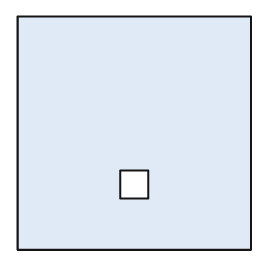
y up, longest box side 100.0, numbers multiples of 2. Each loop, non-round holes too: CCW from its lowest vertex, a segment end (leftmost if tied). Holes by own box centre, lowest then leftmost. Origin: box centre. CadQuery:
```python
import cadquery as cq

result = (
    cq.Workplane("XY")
    .moveTo(-50.0, -50.0)
    .lineTo(50.0, -50.0)
    .lineTo(50.0, 50.0)
    .lineTo(-50.0, 50.0)
    .close()
    .moveTo(-6.0, -28.0)
    .lineTo(6.0, -28.0)
    .lineTo(6.0, -16.0)
    .lineTo(-6.0, -16.0)
    .close()
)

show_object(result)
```